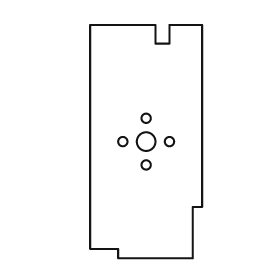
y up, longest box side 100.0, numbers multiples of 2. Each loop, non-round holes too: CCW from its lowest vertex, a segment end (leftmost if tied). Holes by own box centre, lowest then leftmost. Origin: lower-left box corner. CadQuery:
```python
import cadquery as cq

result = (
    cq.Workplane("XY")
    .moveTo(12.0, 0.0)
    .lineTo(44.0, 0.0)
    .lineTo(44.0, 22.0)
    .lineTo(48.0, 22.0)
    .lineTo(48.0, 100.0)
    .lineTo(34.0, 100.0)
    .lineTo(34.0, 92.0)
    .lineTo(28.0, 92.0)
    .lineTo(28.0, 100.0)
    .lineTo(0.0, 100.0)
    .lineTo(0.0, 4.0)
    .lineTo(12.0, 4.0)
    .close()
    .moveTo(24.0, 40.0)
    .circle(2.0)
    .moveTo(14.0, 50.0)
    .circle(2.0)
    .moveTo(24.0, 50.0)
    .circle(4.0)
    .moveTo(34.0, 50.0)
    .circle(2.0)
    .moveTo(24.0, 60.0)
    .circle(2.0)
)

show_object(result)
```